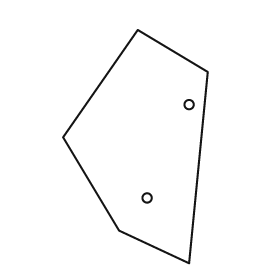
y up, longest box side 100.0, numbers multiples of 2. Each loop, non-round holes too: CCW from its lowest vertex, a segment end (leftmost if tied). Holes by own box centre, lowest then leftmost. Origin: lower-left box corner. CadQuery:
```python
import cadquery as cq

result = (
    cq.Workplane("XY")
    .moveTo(54.0, 0.0)
    .lineTo(62.0, 82.0)
    .lineTo(32.0, 100.0)
    .lineTo(0.0, 54.0)
    .lineTo(24.0, 14.0)
    .close()
    .moveTo(36.0, 28.0)
    .circle(2.0)
    .moveTo(54.0, 68.0)
    .circle(2.0)
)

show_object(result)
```